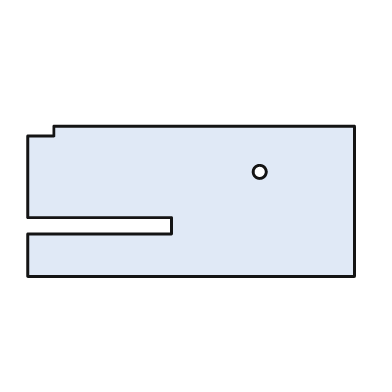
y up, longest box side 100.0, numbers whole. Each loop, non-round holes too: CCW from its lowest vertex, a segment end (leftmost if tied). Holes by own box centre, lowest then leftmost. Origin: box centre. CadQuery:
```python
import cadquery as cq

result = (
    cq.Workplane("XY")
    .moveTo(-50.0, -23.0)
    .lineTo(50.0, -23.0)
    .lineTo(50.0, 23.0)
    .lineTo(-42.0, 23.0)
    .lineTo(-42.0, 20.0)
    .lineTo(-50.0, 20.0)
    .lineTo(-50.0, -5.0)
    .lineTo(-6.0, -5.0)
    .lineTo(-6.0, -10.0)
    .lineTo(-50.0, -10.0)
    .close()
    .moveTo(21.0, 9.0)
    .circle(2.0)
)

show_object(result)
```